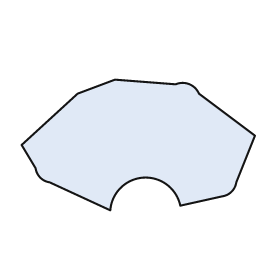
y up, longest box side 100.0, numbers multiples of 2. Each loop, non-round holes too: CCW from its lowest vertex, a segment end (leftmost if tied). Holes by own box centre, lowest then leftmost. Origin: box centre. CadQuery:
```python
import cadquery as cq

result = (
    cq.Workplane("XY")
    .moveTo(-12.0, -28.0)
    .threePointArc((2.0, -14.0), (18.0, -26.0))
    .lineTo(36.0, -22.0)
    .threePointArc((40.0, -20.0), (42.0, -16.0))
    .lineTo(50.0, 4.0)
    .lineTo(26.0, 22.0)
    .threePointArc((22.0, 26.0), (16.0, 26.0))
    .lineTo(-10.0, 28.0)
    .lineTo(-26.0, 22.0)
    .lineTo(-50.0, 0.0)
    .lineTo(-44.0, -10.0)
    .threePointArc((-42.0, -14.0), (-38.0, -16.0))
    .close()
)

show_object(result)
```